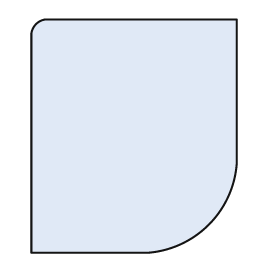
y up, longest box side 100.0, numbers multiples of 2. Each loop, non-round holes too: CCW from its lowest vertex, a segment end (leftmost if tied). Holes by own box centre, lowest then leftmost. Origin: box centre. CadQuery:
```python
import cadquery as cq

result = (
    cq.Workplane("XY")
    .moveTo(-44.0, -50.0)
    .lineTo(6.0, -50.0)
    .threePointArc((32.0, -38.0), (44.0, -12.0))
    .lineTo(44.0, 50.0)
    .lineTo(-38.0, 50.0)
    .threePointArc((-42.0, 48.0), (-44.0, 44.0))
    .close()
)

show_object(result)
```